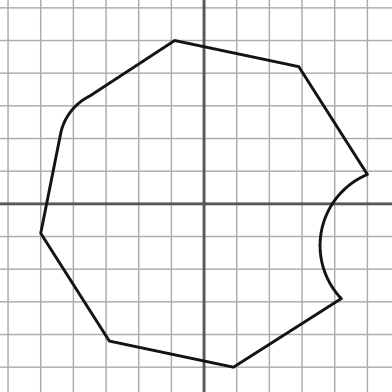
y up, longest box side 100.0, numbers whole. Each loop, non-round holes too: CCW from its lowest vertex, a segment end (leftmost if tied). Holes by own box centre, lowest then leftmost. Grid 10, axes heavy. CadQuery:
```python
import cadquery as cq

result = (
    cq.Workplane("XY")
    .moveTo(9.0, -50.0)
    .lineTo(42.0, -29.0)
    .threePointArc((36.0, -8.0), (50.0, 9.0))
    .lineTo(29.0, 42.0)
    .lineTo(-9.0, 50.0)
    .lineTo(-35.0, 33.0)
    .threePointArc((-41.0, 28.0), (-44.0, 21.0))
    .lineTo(-50.0, -9.0)
    .lineTo(-29.0, -42.0)
    .close()
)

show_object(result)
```